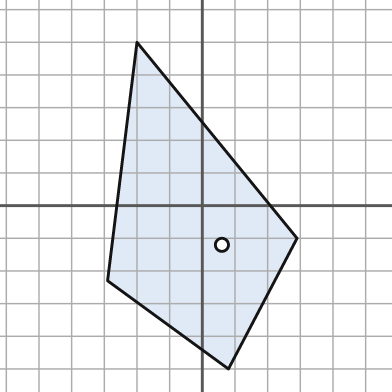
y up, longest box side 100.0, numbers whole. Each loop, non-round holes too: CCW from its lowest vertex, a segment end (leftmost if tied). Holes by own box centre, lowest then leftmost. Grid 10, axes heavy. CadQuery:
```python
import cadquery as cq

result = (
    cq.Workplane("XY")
    .moveTo(8.0, -50.0)
    .lineTo(29.0, -10.0)
    .lineTo(-20.0, 50.0)
    .lineTo(-29.0, -23.0)
    .close()
    .moveTo(6.0, -12.0)
    .circle(2.0)
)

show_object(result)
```